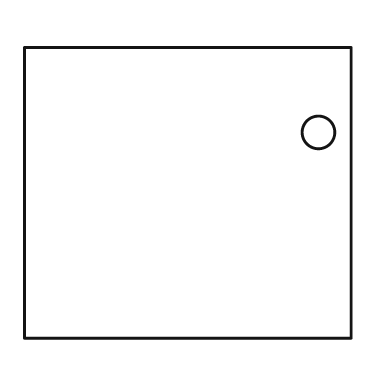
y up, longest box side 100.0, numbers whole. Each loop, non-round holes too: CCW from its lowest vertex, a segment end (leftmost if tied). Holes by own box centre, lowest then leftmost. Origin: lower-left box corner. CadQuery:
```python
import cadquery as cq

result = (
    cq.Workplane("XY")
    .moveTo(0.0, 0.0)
    .lineTo(100.0, 0.0)
    .lineTo(100.0, 89.0)
    .lineTo(0.0, 89.0)
    .close()
    .moveTo(90.0, 63.0)
    .circle(5.0)
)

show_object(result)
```